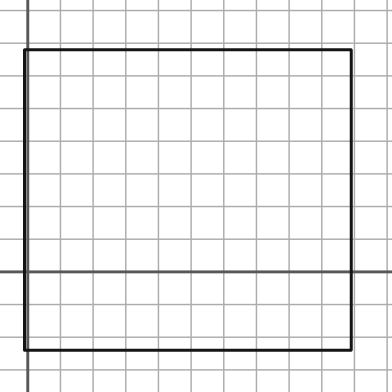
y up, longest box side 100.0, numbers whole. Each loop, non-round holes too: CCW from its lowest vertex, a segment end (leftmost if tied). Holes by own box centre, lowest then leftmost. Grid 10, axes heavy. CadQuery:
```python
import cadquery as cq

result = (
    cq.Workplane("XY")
    .moveTo(-1.0, -24.0)
    .lineTo(99.0, -24.0)
    .lineTo(99.0, 68.0)
    .lineTo(-1.0, 68.0)
    .close()
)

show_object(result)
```